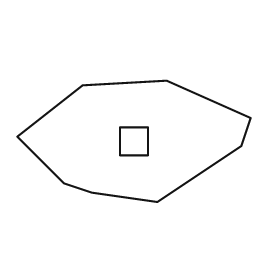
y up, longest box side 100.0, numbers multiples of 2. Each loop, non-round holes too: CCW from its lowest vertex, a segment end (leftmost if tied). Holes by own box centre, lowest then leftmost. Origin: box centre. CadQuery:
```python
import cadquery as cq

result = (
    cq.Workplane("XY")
    .moveTo(10.0, -26.0)
    .lineTo(46.0, -2.0)
    .lineTo(50.0, 10.0)
    .lineTo(14.0, 26.0)
    .lineTo(-22.0, 24.0)
    .lineTo(-50.0, 2.0)
    .lineTo(-30.0, -18.0)
    .lineTo(-18.0, -22.0)
    .close()
    .moveTo(-6.0, -6.0)
    .lineTo(6.0, -6.0)
    .lineTo(6.0, 6.0)
    .lineTo(-6.0, 6.0)
    .close()
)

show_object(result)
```